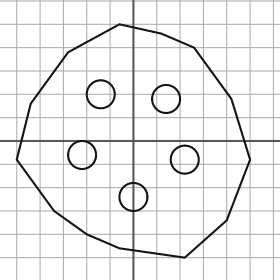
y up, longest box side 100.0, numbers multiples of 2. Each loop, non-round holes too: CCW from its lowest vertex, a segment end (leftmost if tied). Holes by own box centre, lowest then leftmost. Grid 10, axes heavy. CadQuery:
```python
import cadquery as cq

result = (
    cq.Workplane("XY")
    .moveTo(22.0, -50.0)
    .lineTo(40.0, -34.0)
    .lineTo(50.0, -8.0)
    .lineTo(42.0, 18.0)
    .lineTo(26.0, 40.0)
    .lineTo(12.0, 46.0)
    .lineTo(-6.0, 50.0)
    .lineTo(-28.0, 38.0)
    .lineTo(-44.0, 16.0)
    .lineTo(-50.0, -8.0)
    .lineTo(-34.0, -30.0)
    .lineTo(-20.0, -40.0)
    .lineTo(-6.0, -46.0)
    .close()
    .moveTo(0.0, -24.0)
    .circle(6.0)
    .moveTo(22.0, -8.0)
    .circle(6.0)
    .moveTo(-22.0, -6.0)
    .circle(6.0)
    .moveTo(14.0, 18.0)
    .circle(6.0)
    .moveTo(-14.0, 20.0)
    .circle(6.0)
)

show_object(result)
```